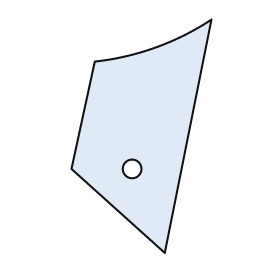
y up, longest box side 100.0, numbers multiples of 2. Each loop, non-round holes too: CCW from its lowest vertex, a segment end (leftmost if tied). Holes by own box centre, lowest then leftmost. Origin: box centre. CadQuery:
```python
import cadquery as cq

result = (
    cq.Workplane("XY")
    .moveTo(10.0, -50.0)
    .lineTo(30.0, 50.0)
    .threePointArc((6.0, 38.0), (-20.0, 32.0))
    .lineTo(-30.0, -14.0)
    .close()
    .moveTo(-4.0, -14.0)
    .circle(4.0)
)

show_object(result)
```